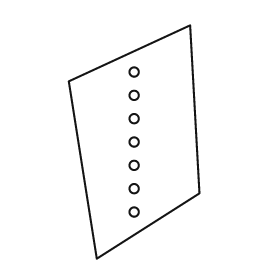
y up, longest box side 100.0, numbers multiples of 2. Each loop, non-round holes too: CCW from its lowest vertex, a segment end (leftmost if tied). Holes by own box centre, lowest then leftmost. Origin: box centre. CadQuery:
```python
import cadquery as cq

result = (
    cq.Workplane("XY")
    .moveTo(-16.0, -50.0)
    .lineTo(28.0, -22.0)
    .lineTo(24.0, 50.0)
    .lineTo(-28.0, 26.0)
    .close()
    .moveTo(0.0, -30.0)
    .circle(2.0)
    .moveTo(0.0, -20.0)
    .circle(2.0)
    .moveTo(0.0, -10.0)
    .circle(2.0)
    .moveTo(0.0, 0.0)
    .circle(2.0)
    .moveTo(0.0, 10.0)
    .circle(2.0)
    .moveTo(0.0, 20.0)
    .circle(2.0)
    .moveTo(0.0, 30.0)
    .circle(2.0)
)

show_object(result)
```